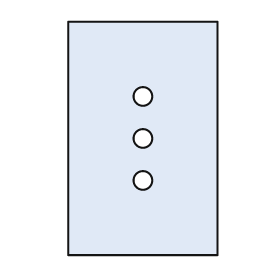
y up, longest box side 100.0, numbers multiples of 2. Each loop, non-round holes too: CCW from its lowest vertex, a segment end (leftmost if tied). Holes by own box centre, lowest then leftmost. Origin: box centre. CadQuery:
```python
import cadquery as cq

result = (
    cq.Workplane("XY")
    .moveTo(-32.0, -50.0)
    .lineTo(32.0, -50.0)
    .lineTo(32.0, 50.0)
    .lineTo(-32.0, 50.0)
    .close()
    .moveTo(0.0, -18.0)
    .circle(4.0)
    .moveTo(0.0, 0.0)
    .circle(4.0)
    .moveTo(0.0, 18.0)
    .circle(4.0)
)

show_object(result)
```